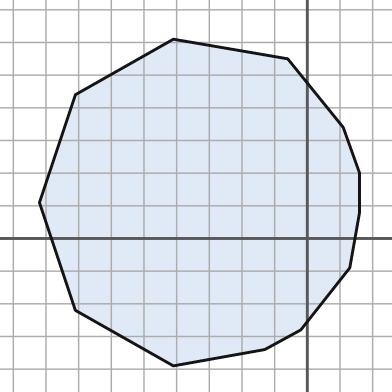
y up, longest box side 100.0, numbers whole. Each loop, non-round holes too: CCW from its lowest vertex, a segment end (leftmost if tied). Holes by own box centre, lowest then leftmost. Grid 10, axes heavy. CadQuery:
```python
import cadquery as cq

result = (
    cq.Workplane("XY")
    .moveTo(-41.0, -39.0)
    .lineTo(-13.0, -34.0)
    .lineTo(-2.0, -28.0)
    .lineTo(13.0, -9.0)
    .lineTo(16.0, 8.0)
    .lineTo(16.0, 20.0)
    .lineTo(11.0, 34.0)
    .lineTo(-6.0, 55.0)
    .lineTo(-41.0, 61.0)
    .lineTo(-71.0, 44.0)
    .lineTo(-82.0, 11.0)
    .lineTo(-71.0, -22.0)
    .close()
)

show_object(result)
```